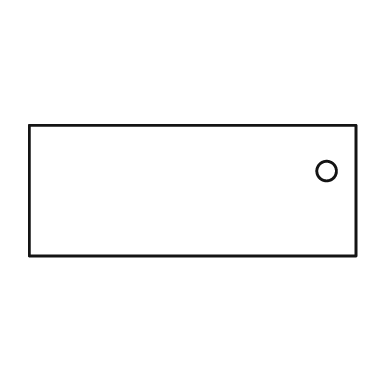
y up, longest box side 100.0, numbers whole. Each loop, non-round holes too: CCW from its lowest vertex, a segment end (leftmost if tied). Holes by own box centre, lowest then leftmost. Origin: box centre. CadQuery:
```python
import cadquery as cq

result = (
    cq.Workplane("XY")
    .moveTo(-50.0, -20.0)
    .lineTo(50.0, -20.0)
    .lineTo(50.0, 20.0)
    .lineTo(-50.0, 20.0)
    .close()
    .moveTo(41.0, 6.0)
    .circle(3.0)
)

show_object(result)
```